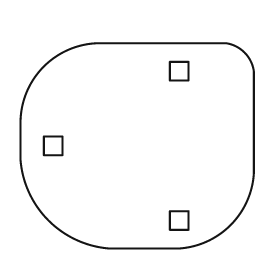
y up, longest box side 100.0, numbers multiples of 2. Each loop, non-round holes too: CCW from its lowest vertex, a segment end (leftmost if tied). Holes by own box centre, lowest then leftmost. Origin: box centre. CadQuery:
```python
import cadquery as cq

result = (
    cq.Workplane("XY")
    .moveTo(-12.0, -44.0)
    .lineTo(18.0, -44.0)
    .threePointArc((40.0, -34.0), (50.0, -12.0))
    .lineTo(50.0, 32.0)
    .threePointArc((46.0, 40.0), (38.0, 44.0))
    .lineTo(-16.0, 44.0)
    .threePointArc((-40.0, 34.0), (-50.0, 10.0))
    .lineTo(-50.0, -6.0)
    .threePointArc((-38.0, -32.0), (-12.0, -44.0))
    .close()
    .moveTo(14.0, -36.0)
    .lineTo(22.0, -36.0)
    .lineTo(22.0, -28.0)
    .lineTo(14.0, -28.0)
    .close()
    .moveTo(-40.0, -4.0)
    .lineTo(-32.0, -4.0)
    .lineTo(-32.0, 4.0)
    .lineTo(-40.0, 4.0)
    .close()
    .moveTo(14.0, 28.0)
    .lineTo(22.0, 28.0)
    .lineTo(22.0, 36.0)
    .lineTo(14.0, 36.0)
    .close()
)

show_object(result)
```